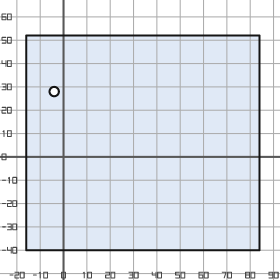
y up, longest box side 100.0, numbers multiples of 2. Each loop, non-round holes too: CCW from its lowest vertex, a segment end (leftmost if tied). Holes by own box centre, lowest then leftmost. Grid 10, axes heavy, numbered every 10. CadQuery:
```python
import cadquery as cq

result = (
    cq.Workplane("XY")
    .moveTo(-16.0, -40.0)
    .lineTo(84.0, -40.0)
    .lineTo(84.0, 52.0)
    .lineTo(-16.0, 52.0)
    .close()
    .moveTo(-4.0, 28.0)
    .circle(2.0)
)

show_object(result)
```